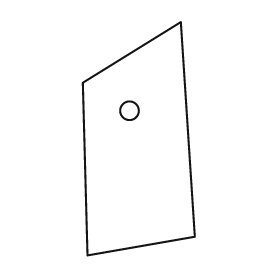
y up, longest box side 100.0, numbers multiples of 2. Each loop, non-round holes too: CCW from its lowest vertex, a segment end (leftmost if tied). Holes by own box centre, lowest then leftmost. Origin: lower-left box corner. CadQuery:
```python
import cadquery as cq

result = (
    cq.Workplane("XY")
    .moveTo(2.0, 0.0)
    .lineTo(48.0, 8.0)
    .lineTo(42.0, 100.0)
    .lineTo(0.0, 74.0)
    .close()
    .moveTo(20.0, 62.0)
    .circle(4.0)
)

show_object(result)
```